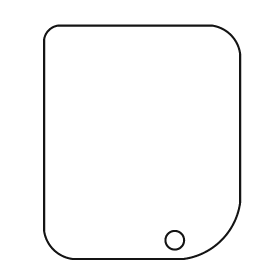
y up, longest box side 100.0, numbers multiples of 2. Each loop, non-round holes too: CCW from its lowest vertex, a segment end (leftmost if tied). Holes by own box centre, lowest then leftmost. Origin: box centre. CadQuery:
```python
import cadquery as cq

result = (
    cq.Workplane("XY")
    .moveTo(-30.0, -50.0)
    .lineTo(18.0, -50.0)
    .threePointArc((34.0, -42.0), (42.0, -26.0))
    .lineTo(42.0, 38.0)
    .threePointArc((38.0, 46.0), (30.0, 50.0))
    .lineTo(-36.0, 50.0)
    .threePointArc((-40.0, 48.0), (-42.0, 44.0))
    .lineTo(-42.0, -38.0)
    .threePointArc((-38.0, -46.0), (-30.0, -50.0))
    .close()
    .moveTo(14.0, -42.0)
    .circle(4.0)
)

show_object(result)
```